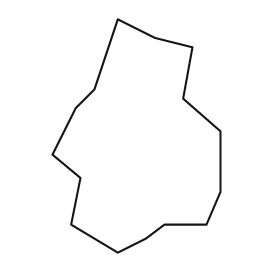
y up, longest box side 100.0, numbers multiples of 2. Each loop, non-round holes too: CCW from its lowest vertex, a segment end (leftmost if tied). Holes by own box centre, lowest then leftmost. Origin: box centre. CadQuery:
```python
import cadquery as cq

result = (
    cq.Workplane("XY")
    .moveTo(-8.0, -50.0)
    .lineTo(4.0, -44.0)
    .lineTo(12.0, -38.0)
    .lineTo(30.0, -38.0)
    .lineTo(36.0, -24.0)
    .lineTo(36.0, 2.0)
    .lineTo(20.0, 16.0)
    .lineTo(24.0, 38.0)
    .lineTo(8.0, 42.0)
    .lineTo(-8.0, 50.0)
    .lineTo(-18.0, 20.0)
    .lineTo(-26.0, 12.0)
    .lineTo(-36.0, -8.0)
    .lineTo(-24.0, -18.0)
    .lineTo(-28.0, -38.0)
    .close()
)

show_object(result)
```